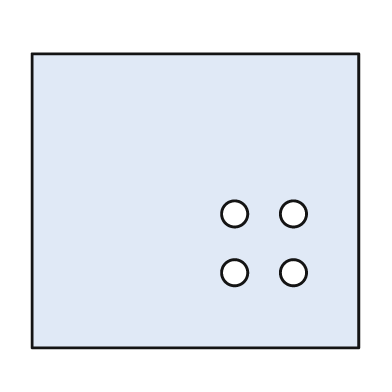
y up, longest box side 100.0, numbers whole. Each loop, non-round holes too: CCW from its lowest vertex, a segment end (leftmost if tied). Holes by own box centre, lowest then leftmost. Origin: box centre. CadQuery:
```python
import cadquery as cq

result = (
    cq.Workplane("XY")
    .moveTo(-50.0, -45.0)
    .lineTo(50.0, -45.0)
    .lineTo(50.0, 45.0)
    .lineTo(-50.0, 45.0)
    .close()
    .moveTo(12.0, -22.0)
    .circle(4.0)
    .moveTo(30.0, -22.0)
    .circle(4.0)
    .moveTo(12.0, -4.0)
    .circle(4.0)
    .moveTo(30.0, -4.0)
    .circle(4.0)
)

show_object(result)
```